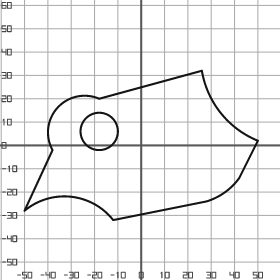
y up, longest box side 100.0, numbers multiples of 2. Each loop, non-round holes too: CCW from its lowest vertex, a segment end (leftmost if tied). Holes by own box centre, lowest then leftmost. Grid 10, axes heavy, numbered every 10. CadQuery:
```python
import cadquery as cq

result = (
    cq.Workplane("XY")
    .moveTo(-12.0, -32.0)
    .lineTo(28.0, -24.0)
    .threePointArc((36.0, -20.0), (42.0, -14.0))
    .lineTo(50.0, 2.0)
    .threePointArc((34.0, 14.0), (26.0, 32.0))
    .lineTo(-18.0, 20.0)
    .threePointArc((-36.0, 16.0), (-38.0, -2.0))
    .lineTo(-50.0, -28.0)
    .threePointArc((-30.0, -22.0), (-12.0, -32.0))
    .close()
    .moveTo(-18.0, 6.0)
    .circle(8.0)
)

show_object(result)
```